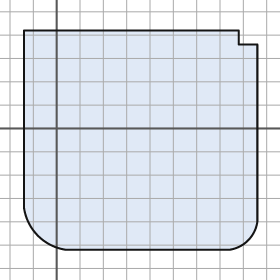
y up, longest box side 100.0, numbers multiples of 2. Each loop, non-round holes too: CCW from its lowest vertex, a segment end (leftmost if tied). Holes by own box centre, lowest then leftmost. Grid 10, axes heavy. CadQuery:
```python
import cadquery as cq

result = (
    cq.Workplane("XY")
    .moveTo(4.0, -52.0)
    .lineTo(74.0, -52.0)
    .threePointArc((82.0, -48.0), (86.0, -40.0))
    .lineTo(86.0, 36.0)
    .lineTo(78.0, 36.0)
    .lineTo(78.0, 42.0)
    .lineTo(-14.0, 42.0)
    .lineTo(-14.0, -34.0)
    .threePointArc((-8.0, -46.0), (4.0, -52.0))
    .close()
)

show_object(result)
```